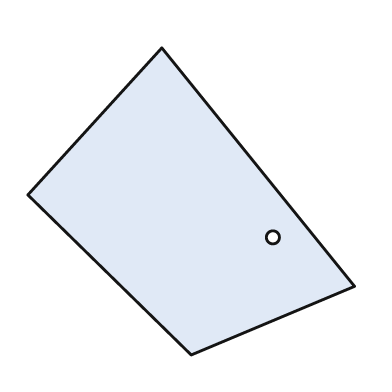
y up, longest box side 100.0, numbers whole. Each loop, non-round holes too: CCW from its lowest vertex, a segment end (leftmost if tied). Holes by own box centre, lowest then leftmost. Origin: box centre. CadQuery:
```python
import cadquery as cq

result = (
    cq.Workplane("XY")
    .moveTo(0.0, -47.0)
    .lineTo(50.0, -26.0)
    .lineTo(-9.0, 47.0)
    .lineTo(-50.0, 2.0)
    .close()
    .moveTo(25.0, -11.0)
    .circle(2.0)
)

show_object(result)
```